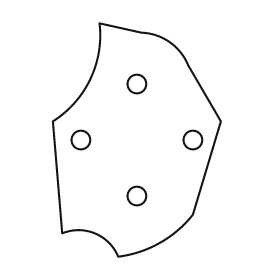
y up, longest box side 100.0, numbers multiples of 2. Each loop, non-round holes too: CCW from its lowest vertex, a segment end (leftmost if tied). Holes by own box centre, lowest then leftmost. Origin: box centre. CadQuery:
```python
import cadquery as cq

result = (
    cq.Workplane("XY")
    .moveTo(-8.0, -50.0)
    .threePointArc((10.0, -44.0), (24.0, -32.0))
    .lineTo(36.0, 8.0)
    .lineTo(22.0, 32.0)
    .threePointArc((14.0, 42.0), (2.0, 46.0))
    .lineTo(-16.0, 50.0)
    .threePointArc((-20.0, 26.0), (-36.0, 8.0))
    .lineTo(-32.0, -40.0)
    .threePointArc((-18.0, -40.0), (-8.0, -50.0))
    .close()
    .moveTo(0.0, -24.0)
    .circle(4.0)
    .moveTo(-24.0, 0.0)
    .circle(4.0)
    .moveTo(24.0, 0.0)
    .circle(4.0)
    .moveTo(0.0, 24.0)
    .circle(4.0)
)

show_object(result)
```